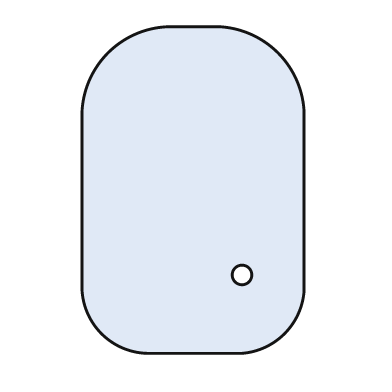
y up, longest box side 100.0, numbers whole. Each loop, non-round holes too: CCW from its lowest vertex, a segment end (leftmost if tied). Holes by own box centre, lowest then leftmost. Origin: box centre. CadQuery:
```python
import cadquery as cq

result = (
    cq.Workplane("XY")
    .moveTo(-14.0, -50.0)
    .lineTo(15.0, -50.0)
    .threePointArc((28.0, -44.0), (34.0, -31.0))
    .lineTo(34.0, 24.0)
    .threePointArc((26.0, 42.0), (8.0, 50.0))
    .lineTo(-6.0, 50.0)
    .threePointArc((-26.0, 42.0), (-34.0, 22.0))
    .lineTo(-34.0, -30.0)
    .threePointArc((-28.0, -44.0), (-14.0, -50.0))
    .close()
    .moveTo(15.0, -26.0)
    .circle(3.0)
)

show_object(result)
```